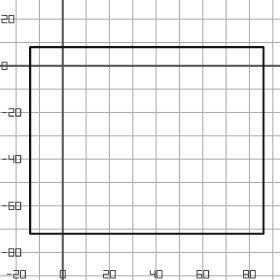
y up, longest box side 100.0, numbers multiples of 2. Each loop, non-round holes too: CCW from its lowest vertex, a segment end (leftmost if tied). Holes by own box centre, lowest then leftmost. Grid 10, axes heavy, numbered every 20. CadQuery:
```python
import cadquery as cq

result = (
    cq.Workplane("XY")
    .moveTo(-14.0, -72.0)
    .lineTo(86.0, -72.0)
    .lineTo(86.0, 8.0)
    .lineTo(-14.0, 8.0)
    .close()
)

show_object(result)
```